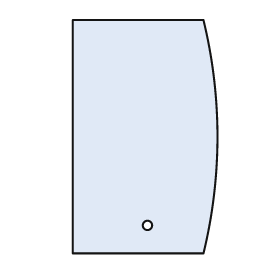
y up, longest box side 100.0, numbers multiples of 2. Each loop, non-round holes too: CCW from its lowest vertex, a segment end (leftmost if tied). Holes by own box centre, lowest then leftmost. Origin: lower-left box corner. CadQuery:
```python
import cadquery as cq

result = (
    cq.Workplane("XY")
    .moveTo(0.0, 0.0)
    .lineTo(56.0, 0.0)
    .threePointArc((62.0, 50.0), (56.0, 100.0))
    .lineTo(0.0, 100.0)
    .close()
    .moveTo(32.0, 12.0)
    .circle(2.0)
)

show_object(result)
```